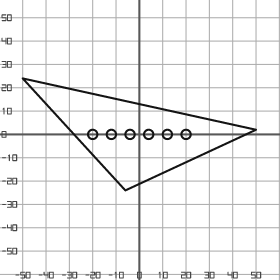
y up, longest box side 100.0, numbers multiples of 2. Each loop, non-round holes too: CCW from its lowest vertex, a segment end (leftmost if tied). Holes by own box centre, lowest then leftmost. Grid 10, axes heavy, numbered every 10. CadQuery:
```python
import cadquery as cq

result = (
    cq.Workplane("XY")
    .moveTo(-6.0, -24.0)
    .lineTo(50.0, 2.0)
    .lineTo(-50.0, 24.0)
    .close()
    .moveTo(-20.0, 0.0)
    .circle(2.0)
    .moveTo(-12.0, 0.0)
    .circle(2.0)
    .moveTo(-4.0, 0.0)
    .circle(2.0)
    .moveTo(4.0, 0.0)
    .circle(2.0)
    .moveTo(12.0, 0.0)
    .circle(2.0)
    .moveTo(20.0, 0.0)
    .circle(2.0)
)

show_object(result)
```